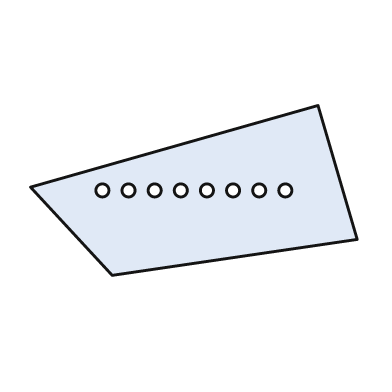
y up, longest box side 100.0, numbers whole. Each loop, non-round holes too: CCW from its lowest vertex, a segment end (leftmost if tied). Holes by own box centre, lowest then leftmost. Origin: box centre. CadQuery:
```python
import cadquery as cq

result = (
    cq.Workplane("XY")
    .moveTo(-25.0, -26.0)
    .lineTo(50.0, -15.0)
    .lineTo(38.0, 26.0)
    .lineTo(-50.0, 1.0)
    .close()
    .moveTo(-28.0, 0.0)
    .circle(2.0)
    .moveTo(-20.0, 0.0)
    .circle(2.0)
    .moveTo(-12.0, 0.0)
    .circle(2.0)
    .moveTo(-4.0, 0.0)
    .circle(2.0)
    .moveTo(4.0, 0.0)
    .circle(2.0)
    .moveTo(12.0, 0.0)
    .circle(2.0)
    .moveTo(20.0, 0.0)
    .circle(2.0)
    .moveTo(28.0, 0.0)
    .circle(2.0)
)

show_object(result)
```